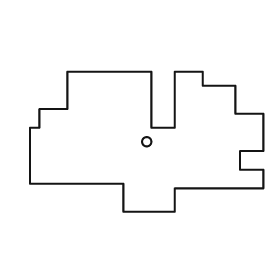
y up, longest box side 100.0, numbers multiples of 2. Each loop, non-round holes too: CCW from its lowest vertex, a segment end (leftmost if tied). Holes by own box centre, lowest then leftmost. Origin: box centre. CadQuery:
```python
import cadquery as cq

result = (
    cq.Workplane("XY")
    .moveTo(-10.0, -30.0)
    .lineTo(12.0, -30.0)
    .lineTo(12.0, -20.0)
    .lineTo(50.0, -20.0)
    .lineTo(50.0, -12.0)
    .lineTo(40.0, -12.0)
    .lineTo(40.0, -4.0)
    .lineTo(50.0, -4.0)
    .lineTo(50.0, 12.0)
    .lineTo(38.0, 12.0)
    .lineTo(38.0, 24.0)
    .lineTo(24.0, 24.0)
    .lineTo(24.0, 30.0)
    .lineTo(12.0, 30.0)
    .lineTo(12.0, 6.0)
    .lineTo(2.0, 6.0)
    .lineTo(2.0, 30.0)
    .lineTo(-34.0, 30.0)
    .lineTo(-34.0, 14.0)
    .lineTo(-46.0, 14.0)
    .lineTo(-46.0, 6.0)
    .lineTo(-50.0, 6.0)
    .lineTo(-50.0, -18.0)
    .lineTo(-10.0, -18.0)
    .close()
    .moveTo(0.0, 0.0)
    .circle(2.0)
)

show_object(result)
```